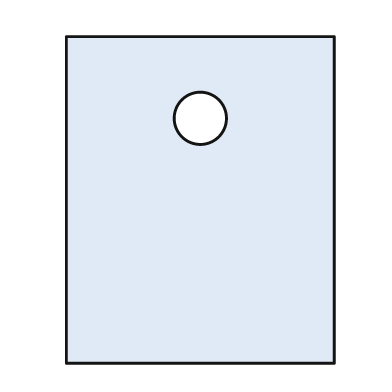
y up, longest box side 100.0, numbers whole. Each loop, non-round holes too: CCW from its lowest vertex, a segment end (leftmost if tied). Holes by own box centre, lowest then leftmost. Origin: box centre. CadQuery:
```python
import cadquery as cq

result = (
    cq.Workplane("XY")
    .moveTo(-41.0, -50.0)
    .lineTo(41.0, -50.0)
    .lineTo(41.0, 50.0)
    .lineTo(-41.0, 50.0)
    .close()
    .moveTo(0.0, 25.0)
    .circle(8.0)
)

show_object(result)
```